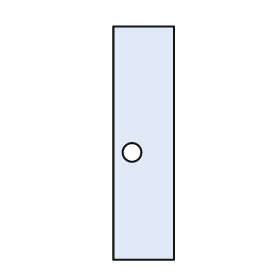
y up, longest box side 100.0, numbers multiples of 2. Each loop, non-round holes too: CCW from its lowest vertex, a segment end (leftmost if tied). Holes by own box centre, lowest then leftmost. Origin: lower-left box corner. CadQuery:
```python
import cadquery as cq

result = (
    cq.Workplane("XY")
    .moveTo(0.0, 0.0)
    .lineTo(26.0, 0.0)
    .lineTo(26.0, 100.0)
    .lineTo(0.0, 100.0)
    .close()
    .moveTo(8.0, 46.0)
    .circle(4.0)
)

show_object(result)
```